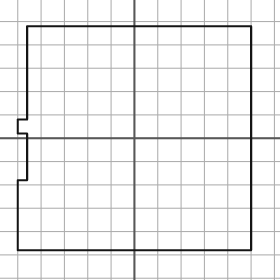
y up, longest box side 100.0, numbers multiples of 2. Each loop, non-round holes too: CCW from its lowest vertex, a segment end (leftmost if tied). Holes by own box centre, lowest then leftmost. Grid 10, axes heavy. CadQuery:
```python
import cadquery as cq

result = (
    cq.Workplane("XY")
    .moveTo(-50.0, -48.0)
    .lineTo(50.0, -48.0)
    .lineTo(50.0, 48.0)
    .lineTo(-46.0, 48.0)
    .lineTo(-46.0, 8.0)
    .lineTo(-50.0, 8.0)
    .lineTo(-50.0, 2.0)
    .lineTo(-46.0, 2.0)
    .lineTo(-46.0, -18.0)
    .lineTo(-50.0, -18.0)
    .close()
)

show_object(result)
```